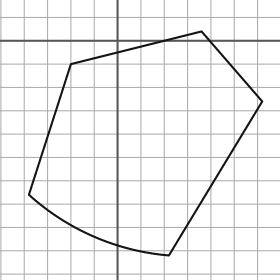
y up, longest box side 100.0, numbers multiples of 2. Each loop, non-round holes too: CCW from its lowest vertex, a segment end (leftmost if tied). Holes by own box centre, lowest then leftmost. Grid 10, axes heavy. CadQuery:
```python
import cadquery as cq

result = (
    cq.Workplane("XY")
    .moveTo(22.0, -92.0)
    .lineTo(62.0, -26.0)
    .lineTo(36.0, 4.0)
    .lineTo(-20.0, -10.0)
    .lineTo(-38.0, -66.0)
    .threePointArc((-10.0, -84.0), (22.0, -92.0))
    .close()
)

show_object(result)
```